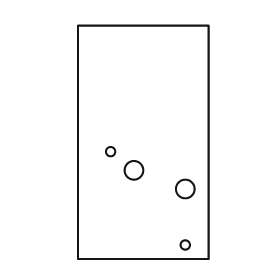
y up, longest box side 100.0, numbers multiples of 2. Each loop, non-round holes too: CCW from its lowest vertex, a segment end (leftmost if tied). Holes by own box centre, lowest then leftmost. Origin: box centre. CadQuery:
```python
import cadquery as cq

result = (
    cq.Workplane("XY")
    .moveTo(-28.0, -50.0)
    .lineTo(28.0, -50.0)
    .lineTo(28.0, 50.0)
    .lineTo(-28.0, 50.0)
    .close()
    .moveTo(18.0, -44.0)
    .circle(2.0)
    .moveTo(18.0, -20.0)
    .circle(4.0)
    .moveTo(-4.0, -12.0)
    .circle(4.0)
    .moveTo(-14.0, -4.0)
    .circle(2.0)
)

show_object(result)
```